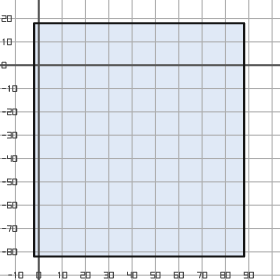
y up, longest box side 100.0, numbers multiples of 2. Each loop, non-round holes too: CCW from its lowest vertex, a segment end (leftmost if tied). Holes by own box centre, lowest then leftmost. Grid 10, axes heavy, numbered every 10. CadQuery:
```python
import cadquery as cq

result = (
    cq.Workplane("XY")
    .moveTo(-2.0, -82.0)
    .lineTo(88.0, -82.0)
    .lineTo(88.0, 18.0)
    .lineTo(-2.0, 18.0)
    .close()
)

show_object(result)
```